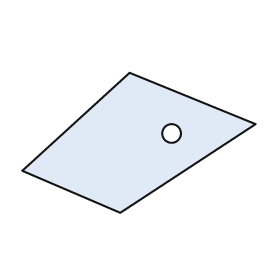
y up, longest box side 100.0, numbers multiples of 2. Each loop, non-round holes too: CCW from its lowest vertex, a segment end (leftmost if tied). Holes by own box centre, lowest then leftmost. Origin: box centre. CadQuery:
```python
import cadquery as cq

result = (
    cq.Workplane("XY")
    .moveTo(-8.0, -30.0)
    .lineTo(50.0, 8.0)
    .lineTo(-4.0, 30.0)
    .lineTo(-50.0, -12.0)
    .close()
    .moveTo(14.0, 4.0)
    .circle(4.0)
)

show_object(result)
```